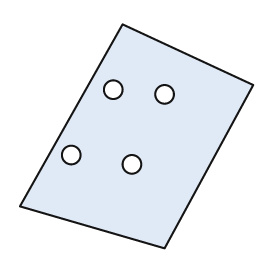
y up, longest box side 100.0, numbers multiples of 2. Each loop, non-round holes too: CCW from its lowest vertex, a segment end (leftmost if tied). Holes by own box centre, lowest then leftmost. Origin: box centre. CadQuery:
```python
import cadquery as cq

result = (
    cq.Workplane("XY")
    .moveTo(12.0, -48.0)
    .lineTo(50.0, 22.0)
    .lineTo(-6.0, 48.0)
    .lineTo(-50.0, -30.0)
    .close()
    .moveTo(-2.0, -12.0)
    .circle(4.0)
    .moveTo(-28.0, -8.0)
    .circle(4.0)
    .moveTo(12.0, 18.0)
    .circle(4.0)
    .moveTo(-10.0, 20.0)
    .circle(4.0)
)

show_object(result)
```